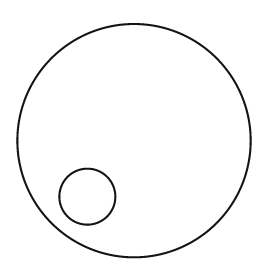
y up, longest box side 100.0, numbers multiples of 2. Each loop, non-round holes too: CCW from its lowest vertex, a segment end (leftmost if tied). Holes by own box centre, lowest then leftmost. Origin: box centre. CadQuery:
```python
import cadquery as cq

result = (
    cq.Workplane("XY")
    .moveTo(0.0, 0.0)
    .circle(50.0)
    .moveTo(-20.0, -24.0)
    .circle(12.0)
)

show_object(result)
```